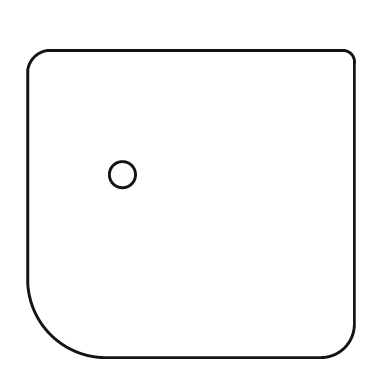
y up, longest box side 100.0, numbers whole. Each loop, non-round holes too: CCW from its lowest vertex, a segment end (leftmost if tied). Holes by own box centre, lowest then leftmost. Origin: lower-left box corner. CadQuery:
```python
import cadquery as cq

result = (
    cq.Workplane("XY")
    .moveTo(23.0, 0.0)
    .lineTo(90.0, 0.0)
    .threePointArc((97.0, 3.0), (100.0, 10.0))
    .lineTo(100.0, 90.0)
    .threePointArc((99.0, 93.0), (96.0, 94.0))
    .lineTo(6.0, 94.0)
    .threePointArc((2.0, 92.0), (0.0, 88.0))
    .lineTo(0.0, 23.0)
    .threePointArc((7.0, 7.0), (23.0, 0.0))
    .close()
    .moveTo(29.0, 56.0)
    .circle(4.0)
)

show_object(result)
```